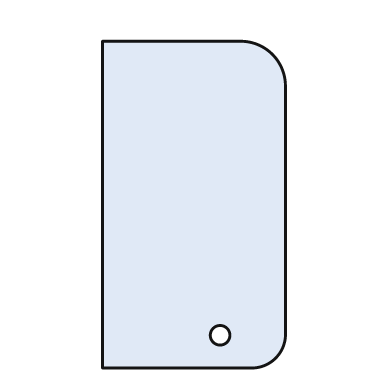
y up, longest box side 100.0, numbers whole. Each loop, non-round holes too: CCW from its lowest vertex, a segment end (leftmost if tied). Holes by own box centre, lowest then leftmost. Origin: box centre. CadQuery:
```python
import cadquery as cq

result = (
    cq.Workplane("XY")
    .moveTo(-28.0, -50.0)
    .lineTo(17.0, -50.0)
    .threePointArc((25.0, -47.0), (28.0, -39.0))
    .lineTo(28.0, 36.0)
    .threePointArc((24.0, 46.0), (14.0, 50.0))
    .lineTo(-28.0, 50.0)
    .close()
    .moveTo(8.0, -40.0)
    .circle(3.0)
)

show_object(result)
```